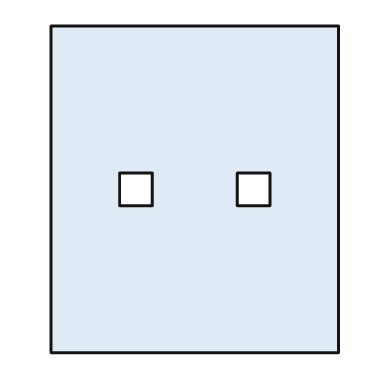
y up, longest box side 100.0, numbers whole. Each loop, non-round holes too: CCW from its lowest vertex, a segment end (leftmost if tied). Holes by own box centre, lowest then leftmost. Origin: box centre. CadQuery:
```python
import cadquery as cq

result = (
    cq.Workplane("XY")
    .moveTo(-44.0, -50.0)
    .lineTo(44.0, -50.0)
    .lineTo(44.0, 50.0)
    .lineTo(-44.0, 50.0)
    .close()
    .moveTo(-23.0, -5.0)
    .lineTo(-13.0, -5.0)
    .lineTo(-13.0, 5.0)
    .lineTo(-23.0, 5.0)
    .close()
    .moveTo(13.0, -5.0)
    .lineTo(23.0, -5.0)
    .lineTo(23.0, 5.0)
    .lineTo(13.0, 5.0)
    .close()
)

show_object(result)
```